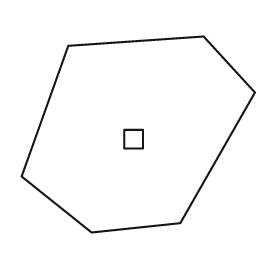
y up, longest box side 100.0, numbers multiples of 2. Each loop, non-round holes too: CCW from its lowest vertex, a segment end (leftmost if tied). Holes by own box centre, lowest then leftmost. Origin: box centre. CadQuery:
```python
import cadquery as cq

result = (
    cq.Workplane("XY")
    .moveTo(-20.0, -42.0)
    .lineTo(18.0, -38.0)
    .lineTo(50.0, 18.0)
    .lineTo(28.0, 42.0)
    .lineTo(-30.0, 38.0)
    .lineTo(-50.0, -18.0)
    .close()
    .moveTo(-6.0, -6.0)
    .lineTo(2.0, -6.0)
    .lineTo(2.0, 2.0)
    .lineTo(-6.0, 2.0)
    .close()
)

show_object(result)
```